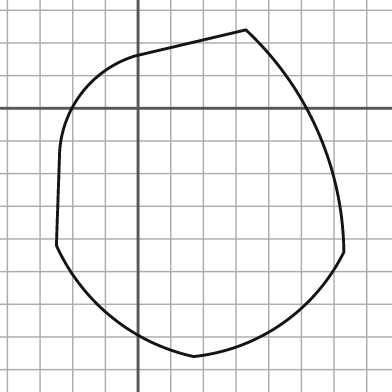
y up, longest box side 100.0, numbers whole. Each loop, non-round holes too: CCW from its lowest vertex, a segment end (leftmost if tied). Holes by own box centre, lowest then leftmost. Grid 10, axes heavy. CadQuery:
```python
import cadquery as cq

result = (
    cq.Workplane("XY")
    .moveTo(17.0, -76.0)
    .threePointArc((44.0, -66.0), (63.0, -44.0))
    .threePointArc((55.0, -7.0), (33.0, 24.0))
    .lineTo(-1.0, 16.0)
    .threePointArc((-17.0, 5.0), (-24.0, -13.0))
    .lineTo(-25.0, -42.0)
    .threePointArc((-8.0, -64.0), (17.0, -76.0))
    .close()
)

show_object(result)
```